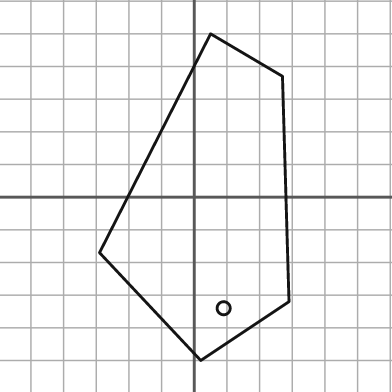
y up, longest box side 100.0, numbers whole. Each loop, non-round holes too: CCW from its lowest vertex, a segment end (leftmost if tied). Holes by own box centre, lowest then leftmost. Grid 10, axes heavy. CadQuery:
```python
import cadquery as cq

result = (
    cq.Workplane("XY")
    .moveTo(2.0, -50.0)
    .lineTo(29.0, -32.0)
    .lineTo(27.0, 37.0)
    .lineTo(5.0, 50.0)
    .lineTo(-29.0, -17.0)
    .close()
    .moveTo(9.0, -34.0)
    .circle(2.0)
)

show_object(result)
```